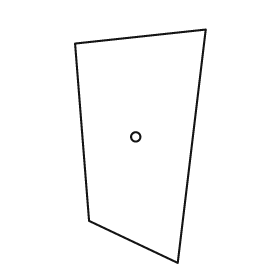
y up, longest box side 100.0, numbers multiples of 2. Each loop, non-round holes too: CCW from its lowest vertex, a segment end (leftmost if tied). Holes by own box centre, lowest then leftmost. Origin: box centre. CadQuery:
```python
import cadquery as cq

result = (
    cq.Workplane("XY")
    .moveTo(16.0, -50.0)
    .lineTo(28.0, 50.0)
    .lineTo(-28.0, 44.0)
    .lineTo(-22.0, -32.0)
    .close()
    .moveTo(-2.0, 4.0)
    .circle(2.0)
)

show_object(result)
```